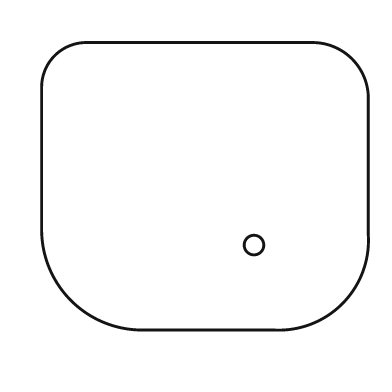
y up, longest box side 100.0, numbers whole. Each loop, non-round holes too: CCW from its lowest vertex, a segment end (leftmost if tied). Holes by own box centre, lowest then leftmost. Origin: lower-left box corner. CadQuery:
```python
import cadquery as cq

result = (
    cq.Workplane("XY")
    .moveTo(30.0, 0.0)
    .lineTo(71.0, 0.0)
    .threePointArc((92.0, 8.0), (100.0, 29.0))
    .lineTo(100.0, 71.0)
    .threePointArc((95.0, 83.0), (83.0, 88.0))
    .lineTo(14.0, 88.0)
    .threePointArc((4.0, 84.0), (0.0, 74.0))
    .lineTo(0.0, 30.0)
    .threePointArc((9.0, 9.0), (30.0, 0.0))
    .close()
    .moveTo(65.0, 26.0)
    .circle(3.0)
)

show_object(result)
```